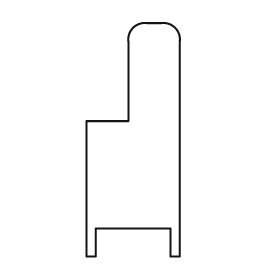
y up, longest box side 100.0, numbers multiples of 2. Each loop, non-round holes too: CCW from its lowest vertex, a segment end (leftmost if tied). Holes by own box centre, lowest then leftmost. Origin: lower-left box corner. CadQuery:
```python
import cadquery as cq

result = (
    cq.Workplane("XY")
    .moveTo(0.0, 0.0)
    .lineTo(4.0, 0.0)
    .lineTo(4.0, 12.0)
    .lineTo(36.0, 12.0)
    .lineTo(36.0, 0.0)
    .lineTo(40.0, 0.0)
    .lineTo(40.0, 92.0)
    .threePointArc((38.0, 98.0), (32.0, 100.0))
    .lineTo(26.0, 100.0)
    .threePointArc((20.0, 98.0), (18.0, 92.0))
    .lineTo(18.0, 58.0)
    .lineTo(0.0, 58.0)
    .close()
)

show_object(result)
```